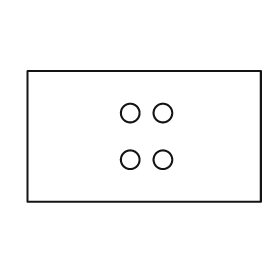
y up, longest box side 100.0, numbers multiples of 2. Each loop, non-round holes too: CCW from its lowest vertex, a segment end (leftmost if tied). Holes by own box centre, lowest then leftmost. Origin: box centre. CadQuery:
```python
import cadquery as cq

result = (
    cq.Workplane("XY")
    .moveTo(-50.0, -28.0)
    .lineTo(50.0, -28.0)
    .lineTo(50.0, 28.0)
    .lineTo(-50.0, 28.0)
    .close()
    .moveTo(-6.0, -10.0)
    .circle(4.0)
    .moveTo(8.0, -10.0)
    .circle(4.0)
    .moveTo(-6.0, 10.0)
    .circle(4.0)
    .moveTo(8.0, 10.0)
    .circle(4.0)
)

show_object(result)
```